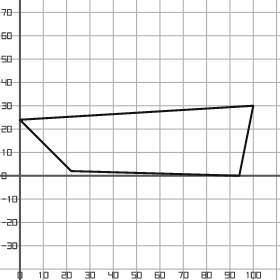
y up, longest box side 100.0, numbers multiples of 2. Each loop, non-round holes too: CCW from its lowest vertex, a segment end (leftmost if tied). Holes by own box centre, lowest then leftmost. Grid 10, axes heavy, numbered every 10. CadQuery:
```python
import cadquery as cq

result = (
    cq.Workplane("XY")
    .moveTo(94.0, 0.0)
    .lineTo(100.0, 30.0)
    .lineTo(0.0, 24.0)
    .lineTo(22.0, 2.0)
    .close()
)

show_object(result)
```